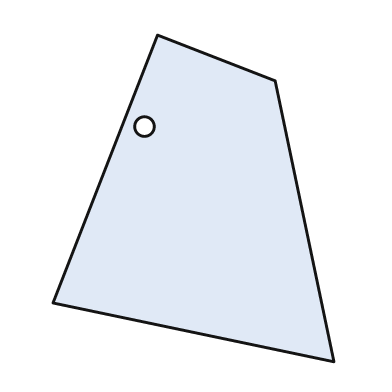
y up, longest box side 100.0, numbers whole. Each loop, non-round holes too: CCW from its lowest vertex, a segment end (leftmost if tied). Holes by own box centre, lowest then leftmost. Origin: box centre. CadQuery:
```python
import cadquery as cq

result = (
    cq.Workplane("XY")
    .moveTo(43.0, -50.0)
    .lineTo(25.0, 36.0)
    .lineTo(-11.0, 50.0)
    .lineTo(-43.0, -32.0)
    .close()
    .moveTo(-15.0, 22.0)
    .circle(3.0)
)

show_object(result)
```